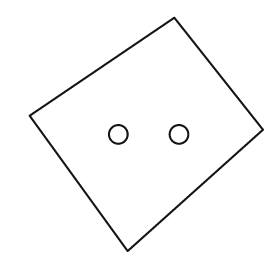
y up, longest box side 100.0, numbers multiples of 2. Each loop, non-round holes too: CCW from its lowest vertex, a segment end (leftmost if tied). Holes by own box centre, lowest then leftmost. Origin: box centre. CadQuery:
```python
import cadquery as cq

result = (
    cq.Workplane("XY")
    .moveTo(-8.0, -50.0)
    .lineTo(50.0, 2.0)
    .lineTo(12.0, 50.0)
    .lineTo(-50.0, 8.0)
    .close()
    .moveTo(-12.0, 0.0)
    .circle(4.0)
    .moveTo(14.0, 0.0)
    .circle(4.0)
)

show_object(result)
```